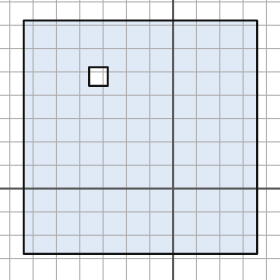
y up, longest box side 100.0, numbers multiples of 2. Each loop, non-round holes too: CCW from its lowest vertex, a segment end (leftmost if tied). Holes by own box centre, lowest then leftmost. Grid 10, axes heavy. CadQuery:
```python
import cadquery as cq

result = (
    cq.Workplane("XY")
    .moveTo(-64.0, -28.0)
    .lineTo(36.0, -28.0)
    .lineTo(36.0, 72.0)
    .lineTo(-64.0, 72.0)
    .close()
    .moveTo(-36.0, 44.0)
    .lineTo(-28.0, 44.0)
    .lineTo(-28.0, 52.0)
    .lineTo(-36.0, 52.0)
    .close()
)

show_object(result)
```